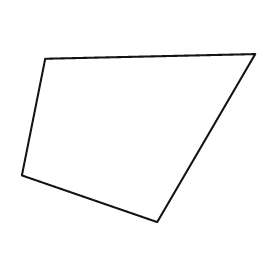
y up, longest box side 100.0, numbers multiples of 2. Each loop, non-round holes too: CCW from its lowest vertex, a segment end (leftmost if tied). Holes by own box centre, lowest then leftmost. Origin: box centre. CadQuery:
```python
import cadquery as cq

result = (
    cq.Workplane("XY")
    .moveTo(8.0, -36.0)
    .lineTo(50.0, 36.0)
    .lineTo(-40.0, 34.0)
    .lineTo(-50.0, -16.0)
    .close()
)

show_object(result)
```